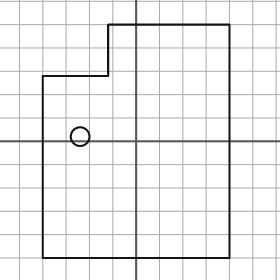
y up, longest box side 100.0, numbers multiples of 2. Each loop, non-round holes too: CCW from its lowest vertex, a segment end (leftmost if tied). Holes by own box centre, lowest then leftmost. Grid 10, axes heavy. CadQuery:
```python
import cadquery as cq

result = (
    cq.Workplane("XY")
    .moveTo(-40.0, -50.0)
    .lineTo(40.0, -50.0)
    .lineTo(40.0, 50.0)
    .lineTo(-12.0, 50.0)
    .lineTo(-12.0, 28.0)
    .lineTo(-40.0, 28.0)
    .close()
    .moveTo(-24.0, 2.0)
    .circle(4.0)
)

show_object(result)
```